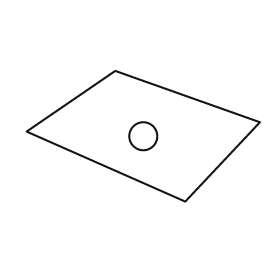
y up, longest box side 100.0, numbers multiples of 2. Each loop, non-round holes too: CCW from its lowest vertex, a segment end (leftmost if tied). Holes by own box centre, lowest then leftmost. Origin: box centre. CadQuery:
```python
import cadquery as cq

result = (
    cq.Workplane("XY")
    .moveTo(18.0, -28.0)
    .lineTo(50.0, 6.0)
    .lineTo(-12.0, 28.0)
    .lineTo(-50.0, 2.0)
    .close()
    .moveTo(0.0, 0.0)
    .circle(6.0)
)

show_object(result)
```